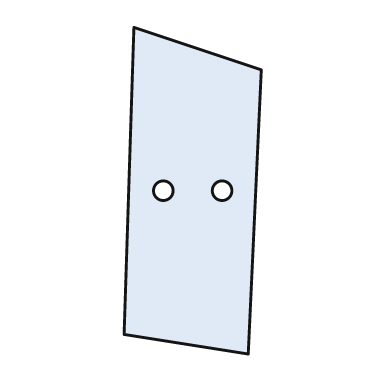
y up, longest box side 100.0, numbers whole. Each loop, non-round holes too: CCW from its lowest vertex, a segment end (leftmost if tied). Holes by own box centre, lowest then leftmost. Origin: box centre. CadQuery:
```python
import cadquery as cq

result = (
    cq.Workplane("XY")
    .moveTo(17.0, -50.0)
    .lineTo(21.0, 37.0)
    .lineTo(-18.0, 50.0)
    .lineTo(-21.0, -44.0)
    .close()
    .moveTo(-9.0, 0.0)
    .circle(3.0)
    .moveTo(9.0, 0.0)
    .circle(3.0)
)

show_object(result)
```